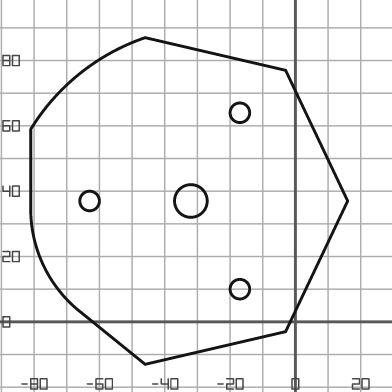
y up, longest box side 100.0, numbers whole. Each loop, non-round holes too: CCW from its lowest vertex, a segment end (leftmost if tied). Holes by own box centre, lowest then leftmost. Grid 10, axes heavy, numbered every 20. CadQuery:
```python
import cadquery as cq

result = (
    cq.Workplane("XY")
    .moveTo(-46.0, -13.0)
    .lineTo(-3.0, -3.0)
    .lineTo(16.0, 37.0)
    .lineTo(-3.0, 77.0)
    .lineTo(-46.0, 87.0)
    .threePointArc((-66.0, 76.0), (-81.0, 59.0))
    .lineTo(-81.0, 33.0)
    .threePointArc((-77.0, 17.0), (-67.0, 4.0))
    .close()
    .moveTo(-17.0, 10.0)
    .circle(3.0)
    .moveTo(-63.0, 37.0)
    .circle(3.0)
    .moveTo(-32.0, 37.0)
    .circle(5.0)
    .moveTo(-17.0, 64.0)
    .circle(3.0)
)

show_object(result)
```